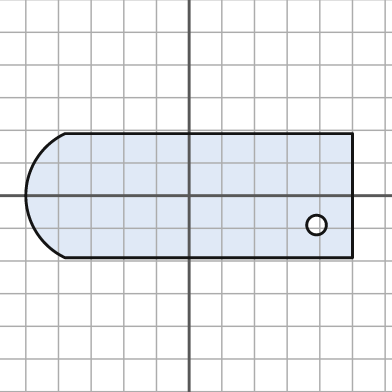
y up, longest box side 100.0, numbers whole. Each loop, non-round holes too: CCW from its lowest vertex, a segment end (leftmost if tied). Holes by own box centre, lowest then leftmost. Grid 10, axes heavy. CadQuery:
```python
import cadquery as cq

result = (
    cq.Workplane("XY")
    .moveTo(-38.0, -19.0)
    .lineTo(50.0, -19.0)
    .lineTo(50.0, 19.0)
    .lineTo(-38.0, 19.0)
    .threePointArc((-50.0, 0.0), (-38.0, -19.0))
    .close()
    .moveTo(39.0, -9.0)
    .circle(3.0)
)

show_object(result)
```